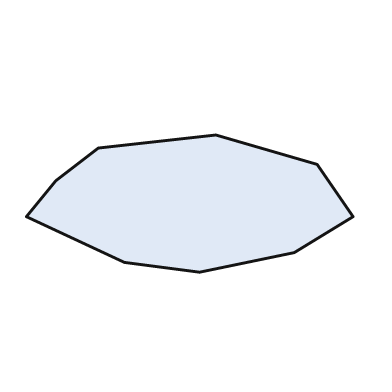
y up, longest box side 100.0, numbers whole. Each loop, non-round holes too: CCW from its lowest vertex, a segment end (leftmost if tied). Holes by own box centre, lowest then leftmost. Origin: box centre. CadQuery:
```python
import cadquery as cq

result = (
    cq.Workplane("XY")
    .moveTo(3.0, -21.0)
    .lineTo(32.0, -15.0)
    .lineTo(50.0, -4.0)
    .lineTo(39.0, 12.0)
    .lineTo(8.0, 21.0)
    .lineTo(-28.0, 17.0)
    .lineTo(-41.0, 7.0)
    .lineTo(-50.0, -4.0)
    .lineTo(-20.0, -18.0)
    .close()
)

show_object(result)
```